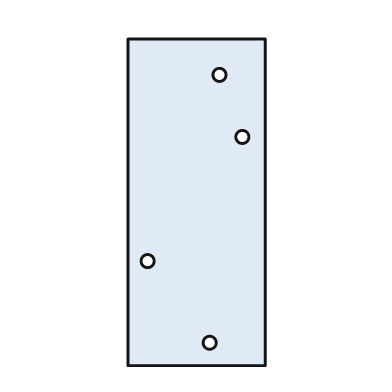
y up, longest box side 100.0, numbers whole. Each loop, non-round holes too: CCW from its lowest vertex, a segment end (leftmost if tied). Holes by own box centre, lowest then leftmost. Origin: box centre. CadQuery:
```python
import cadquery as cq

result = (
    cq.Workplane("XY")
    .moveTo(-21.0, -50.0)
    .lineTo(21.0, -50.0)
    .lineTo(21.0, 50.0)
    .lineTo(-21.0, 50.0)
    .close()
    .moveTo(4.0, -43.0)
    .circle(2.0)
    .moveTo(-15.0, -18.0)
    .circle(2.0)
    .moveTo(14.0, 20.0)
    .circle(2.0)
    .moveTo(7.0, 39.0)
    .circle(2.0)
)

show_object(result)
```